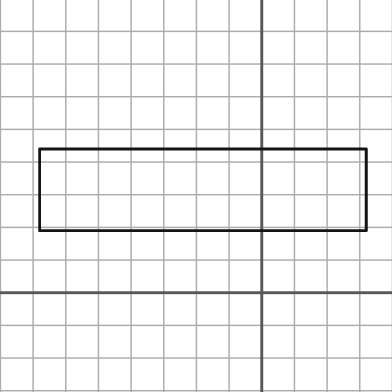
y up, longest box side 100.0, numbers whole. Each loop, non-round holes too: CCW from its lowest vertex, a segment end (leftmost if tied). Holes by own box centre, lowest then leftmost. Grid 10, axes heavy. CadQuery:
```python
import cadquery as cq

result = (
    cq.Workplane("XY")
    .moveTo(-68.0, 19.0)
    .lineTo(32.0, 19.0)
    .lineTo(32.0, 44.0)
    .lineTo(-68.0, 44.0)
    .close()
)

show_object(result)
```